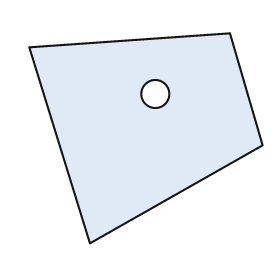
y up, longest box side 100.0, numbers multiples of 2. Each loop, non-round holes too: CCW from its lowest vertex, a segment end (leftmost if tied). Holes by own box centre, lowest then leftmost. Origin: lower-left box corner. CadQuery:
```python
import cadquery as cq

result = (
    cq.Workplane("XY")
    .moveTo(26.0, 0.0)
    .lineTo(100.0, 42.0)
    .lineTo(86.0, 90.0)
    .lineTo(0.0, 84.0)
    .close()
    .moveTo(54.0, 64.0)
    .circle(6.0)
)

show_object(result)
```